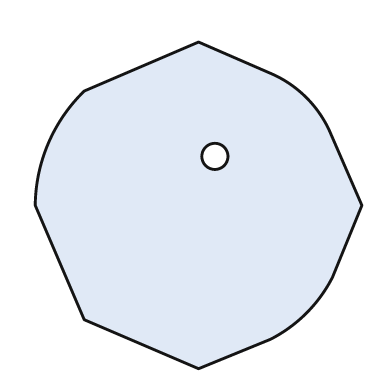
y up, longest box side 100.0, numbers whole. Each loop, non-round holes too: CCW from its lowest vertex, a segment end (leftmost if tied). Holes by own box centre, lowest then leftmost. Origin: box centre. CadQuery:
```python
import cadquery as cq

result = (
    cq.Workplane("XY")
    .moveTo(0.0, -50.0)
    .lineTo(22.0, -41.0)
    .threePointArc((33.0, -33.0), (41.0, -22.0))
    .lineTo(50.0, 0.0)
    .lineTo(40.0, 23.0)
    .threePointArc((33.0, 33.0), (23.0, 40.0))
    .lineTo(0.0, 50.0)
    .lineTo(-35.0, 35.0)
    .threePointArc((-46.0, 19.0), (-50.0, 0.0))
    .lineTo(-35.0, -35.0)
    .close()
    .moveTo(5.0, 15.0)
    .circle(4.0)
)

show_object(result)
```